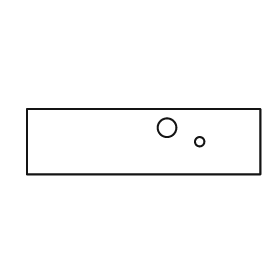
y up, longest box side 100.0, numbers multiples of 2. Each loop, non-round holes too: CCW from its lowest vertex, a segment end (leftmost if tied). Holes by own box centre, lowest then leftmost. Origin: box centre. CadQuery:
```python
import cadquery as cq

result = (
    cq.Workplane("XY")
    .moveTo(-50.0, -14.0)
    .lineTo(50.0, -14.0)
    .lineTo(50.0, 14.0)
    .lineTo(-50.0, 14.0)
    .close()
    .moveTo(24.0, 0.0)
    .circle(2.0)
    .moveTo(10.0, 6.0)
    .circle(4.0)
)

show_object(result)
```